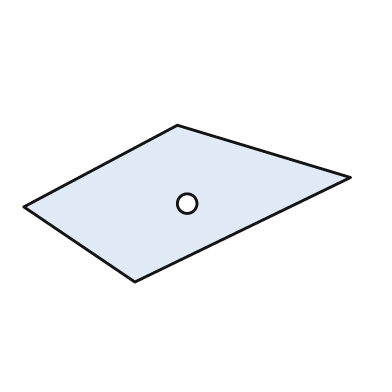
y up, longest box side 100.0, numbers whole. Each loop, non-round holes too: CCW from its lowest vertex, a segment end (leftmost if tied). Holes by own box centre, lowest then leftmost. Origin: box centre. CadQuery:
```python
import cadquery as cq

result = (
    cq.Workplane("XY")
    .moveTo(-16.0, -24.0)
    .lineTo(50.0, 8.0)
    .lineTo(-3.0, 24.0)
    .lineTo(-50.0, -1.0)
    .close()
    .moveTo(0.0, 0.0)
    .circle(3.0)
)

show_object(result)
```